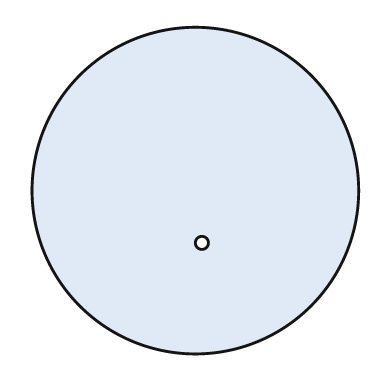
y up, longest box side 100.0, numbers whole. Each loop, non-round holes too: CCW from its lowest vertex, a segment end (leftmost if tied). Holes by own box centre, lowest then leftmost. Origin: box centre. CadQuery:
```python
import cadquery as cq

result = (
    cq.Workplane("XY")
    .moveTo(0.0, 0.0)
    .circle(50.0)
    .moveTo(2.0, -16.0)
    .circle(2.0)
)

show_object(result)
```